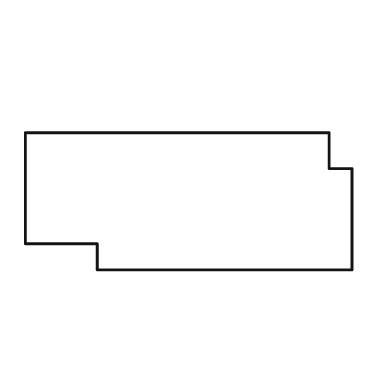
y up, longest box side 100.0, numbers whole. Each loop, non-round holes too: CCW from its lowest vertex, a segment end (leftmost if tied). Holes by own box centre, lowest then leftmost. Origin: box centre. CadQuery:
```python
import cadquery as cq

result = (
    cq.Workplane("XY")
    .moveTo(-28.0, -21.0)
    .lineTo(50.0, -21.0)
    .lineTo(50.0, 10.0)
    .lineTo(43.0, 10.0)
    .lineTo(43.0, 21.0)
    .lineTo(-50.0, 21.0)
    .lineTo(-50.0, -13.0)
    .lineTo(-28.0, -13.0)
    .close()
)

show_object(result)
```